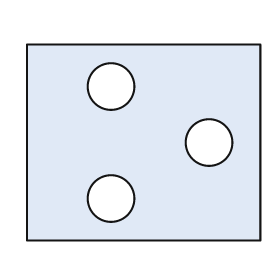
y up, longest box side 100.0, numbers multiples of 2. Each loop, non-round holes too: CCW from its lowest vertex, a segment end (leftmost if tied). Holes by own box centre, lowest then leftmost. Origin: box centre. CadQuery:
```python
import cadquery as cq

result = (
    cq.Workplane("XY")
    .moveTo(-50.0, -42.0)
    .lineTo(50.0, -42.0)
    .lineTo(50.0, 42.0)
    .lineTo(-50.0, 42.0)
    .close()
    .moveTo(-14.0, -24.0)
    .circle(10.0)
    .moveTo(28.0, 0.0)
    .circle(10.0)
    .moveTo(-14.0, 24.0)
    .circle(10.0)
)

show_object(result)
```